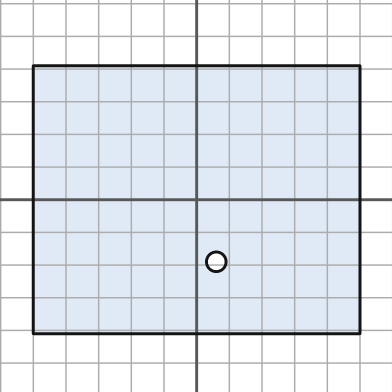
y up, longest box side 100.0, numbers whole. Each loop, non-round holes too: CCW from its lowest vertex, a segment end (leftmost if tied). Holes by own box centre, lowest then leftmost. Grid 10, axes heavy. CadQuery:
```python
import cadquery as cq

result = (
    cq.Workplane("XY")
    .moveTo(-50.0, -41.0)
    .lineTo(50.0, -41.0)
    .lineTo(50.0, 41.0)
    .lineTo(-50.0, 41.0)
    .close()
    .moveTo(6.0, -19.0)
    .circle(3.0)
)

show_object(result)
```